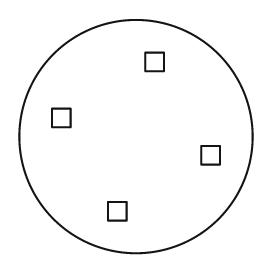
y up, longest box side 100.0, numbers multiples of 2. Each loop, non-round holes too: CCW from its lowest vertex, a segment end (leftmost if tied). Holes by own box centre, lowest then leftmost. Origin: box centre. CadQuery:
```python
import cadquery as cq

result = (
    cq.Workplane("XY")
    .moveTo(0.0, 0.0)
    .circle(50.0)
    .moveTo(-12.0, -36.0)
    .lineTo(-4.0, -36.0)
    .lineTo(-4.0, -28.0)
    .lineTo(-12.0, -28.0)
    .close()
    .moveTo(28.0, -12.0)
    .lineTo(36.0, -12.0)
    .lineTo(36.0, -4.0)
    .lineTo(28.0, -4.0)
    .close()
    .moveTo(-36.0, 4.0)
    .lineTo(-28.0, 4.0)
    .lineTo(-28.0, 12.0)
    .lineTo(-36.0, 12.0)
    .close()
    .moveTo(4.0, 28.0)
    .lineTo(12.0, 28.0)
    .lineTo(12.0, 36.0)
    .lineTo(4.0, 36.0)
    .close()
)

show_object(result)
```